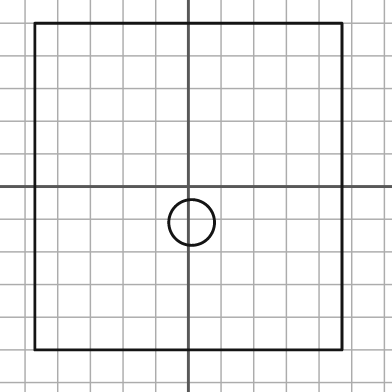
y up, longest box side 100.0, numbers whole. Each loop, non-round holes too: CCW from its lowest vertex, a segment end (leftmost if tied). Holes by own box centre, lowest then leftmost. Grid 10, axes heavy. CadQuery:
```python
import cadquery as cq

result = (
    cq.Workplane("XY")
    .moveTo(-47.0, -50.0)
    .lineTo(47.0, -50.0)
    .lineTo(47.0, 50.0)
    .lineTo(-47.0, 50.0)
    .close()
    .moveTo(1.0, -11.0)
    .circle(7.0)
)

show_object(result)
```